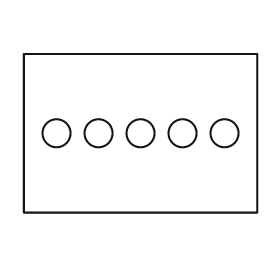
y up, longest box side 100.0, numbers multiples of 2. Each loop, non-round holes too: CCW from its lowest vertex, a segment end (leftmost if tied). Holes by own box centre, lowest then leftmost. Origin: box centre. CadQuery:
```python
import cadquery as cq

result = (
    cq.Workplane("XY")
    .moveTo(-50.0, -34.0)
    .lineTo(50.0, -34.0)
    .lineTo(50.0, 34.0)
    .lineTo(-50.0, 34.0)
    .close()
    .moveTo(-36.0, 0.0)
    .circle(6.0)
    .moveTo(-18.0, 0.0)
    .circle(6.0)
    .moveTo(0.0, 0.0)
    .circle(6.0)
    .moveTo(18.0, 0.0)
    .circle(6.0)
    .moveTo(36.0, 0.0)
    .circle(6.0)
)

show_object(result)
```